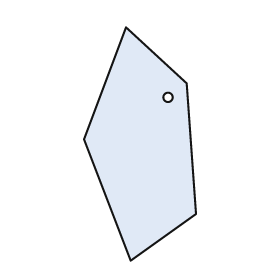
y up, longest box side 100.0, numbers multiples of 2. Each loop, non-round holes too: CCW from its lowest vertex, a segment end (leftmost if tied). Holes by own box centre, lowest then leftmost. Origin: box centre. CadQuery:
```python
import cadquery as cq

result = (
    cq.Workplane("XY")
    .moveTo(-4.0, -50.0)
    .lineTo(24.0, -30.0)
    .lineTo(20.0, 26.0)
    .lineTo(-6.0, 50.0)
    .lineTo(-24.0, 2.0)
    .close()
    .moveTo(12.0, 20.0)
    .circle(2.0)
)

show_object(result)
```